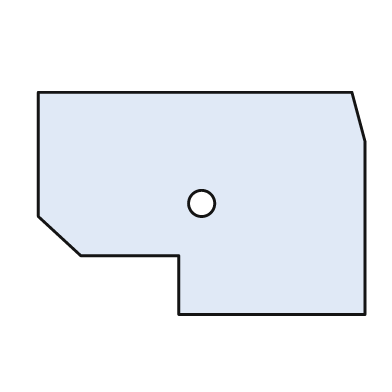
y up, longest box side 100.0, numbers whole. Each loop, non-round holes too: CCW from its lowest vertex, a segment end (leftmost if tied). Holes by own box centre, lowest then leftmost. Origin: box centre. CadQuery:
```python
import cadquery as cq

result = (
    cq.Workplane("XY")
    .moveTo(-7.0, -34.0)
    .lineTo(50.0, -34.0)
    .lineTo(50.0, 19.0)
    .lineTo(46.0, 34.0)
    .lineTo(-50.0, 34.0)
    .lineTo(-50.0, -4.0)
    .lineTo(-37.0, -16.0)
    .lineTo(-7.0, -16.0)
    .close()
    .moveTo(0.0, 0.0)
    .circle(4.0)
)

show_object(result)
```